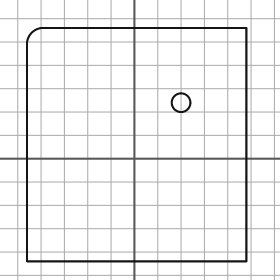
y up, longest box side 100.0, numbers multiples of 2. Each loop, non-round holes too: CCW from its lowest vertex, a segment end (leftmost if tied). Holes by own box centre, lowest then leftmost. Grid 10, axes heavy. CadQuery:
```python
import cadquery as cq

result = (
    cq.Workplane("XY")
    .moveTo(-46.0, -44.0)
    .lineTo(48.0, -44.0)
    .lineTo(48.0, 56.0)
    .lineTo(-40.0, 56.0)
    .threePointArc((-44.0, 54.0), (-46.0, 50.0))
    .close()
    .moveTo(20.0, 24.0)
    .circle(4.0)
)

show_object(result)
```